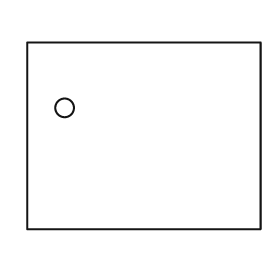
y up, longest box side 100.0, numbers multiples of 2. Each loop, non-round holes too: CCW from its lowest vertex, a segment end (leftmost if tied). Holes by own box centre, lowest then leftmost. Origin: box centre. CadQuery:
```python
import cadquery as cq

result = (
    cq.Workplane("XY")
    .moveTo(-50.0, -40.0)
    .lineTo(50.0, -40.0)
    .lineTo(50.0, 40.0)
    .lineTo(-50.0, 40.0)
    .close()
    .moveTo(-34.0, 12.0)
    .circle(4.0)
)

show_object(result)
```